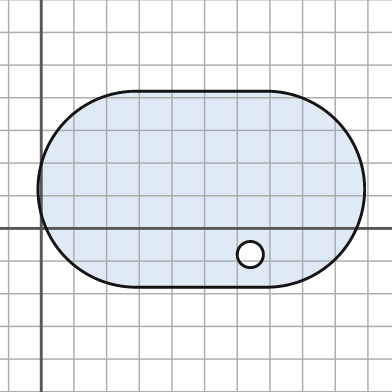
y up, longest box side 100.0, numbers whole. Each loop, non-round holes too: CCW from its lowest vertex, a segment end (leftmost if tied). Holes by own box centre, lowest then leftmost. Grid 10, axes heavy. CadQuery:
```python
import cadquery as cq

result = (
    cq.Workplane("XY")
    .moveTo(29.0, -18.0)
    .lineTo(69.0, -18.0)
    .threePointArc((99.0, 12.0), (69.0, 42.0))
    .lineTo(29.0, 42.0)
    .threePointArc((-1.0, 12.0), (29.0, -18.0))
    .close()
    .moveTo(64.0, -8.0)
    .circle(4.0)
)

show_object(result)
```